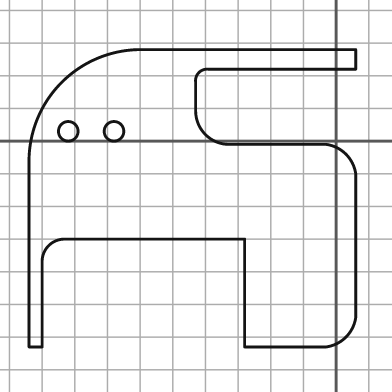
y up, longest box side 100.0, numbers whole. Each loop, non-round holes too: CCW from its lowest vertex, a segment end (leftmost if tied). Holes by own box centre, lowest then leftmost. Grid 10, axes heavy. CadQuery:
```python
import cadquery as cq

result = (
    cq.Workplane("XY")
    .moveTo(-94.0, -63.0)
    .lineTo(-90.0, -63.0)
    .lineTo(-90.0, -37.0)
    .threePointArc((-88.0, -32.0), (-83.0, -30.0))
    .lineTo(-28.0, -30.0)
    .lineTo(-28.0, -63.0)
    .lineTo(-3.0, -63.0)
    .threePointArc((3.0, -60.0), (6.0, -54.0))
    .lineTo(6.0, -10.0)
    .threePointArc((3.0, -4.0), (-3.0, -1.0))
    .lineTo(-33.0, -1.0)
    .threePointArc((-40.0, 2.0), (-43.0, 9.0))
    .lineTo(-43.0, 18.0)
    .threePointArc((-42.0, 21.0), (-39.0, 22.0))
    .lineTo(6.0, 22.0)
    .lineTo(6.0, 28.0)
    .lineTo(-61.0, 28.0)
    .threePointArc((-84.0, 18.0), (-94.0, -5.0))
    .close()
    .moveTo(-82.0, 3.0)
    .circle(3.0)
    .moveTo(-68.0, 3.0)
    .circle(3.0)
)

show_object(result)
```